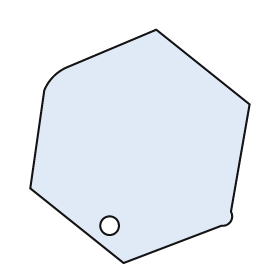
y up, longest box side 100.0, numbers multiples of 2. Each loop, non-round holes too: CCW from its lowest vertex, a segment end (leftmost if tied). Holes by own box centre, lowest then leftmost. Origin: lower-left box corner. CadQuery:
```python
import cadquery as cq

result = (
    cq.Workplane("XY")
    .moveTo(40.0, 0.0)
    .lineTo(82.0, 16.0)
    .threePointArc((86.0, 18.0), (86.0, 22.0))
    .lineTo(94.0, 68.0)
    .lineTo(54.0, 100.0)
    .lineTo(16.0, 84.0)
    .threePointArc((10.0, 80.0), (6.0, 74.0))
    .lineTo(0.0, 32.0)
    .close()
    .moveTo(34.0, 16.0)
    .circle(4.0)
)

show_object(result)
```